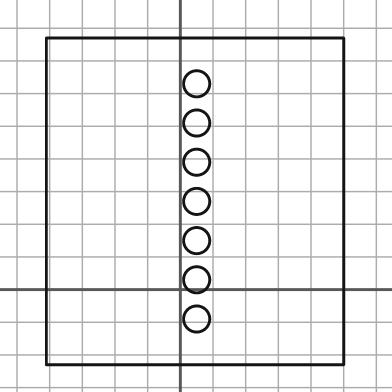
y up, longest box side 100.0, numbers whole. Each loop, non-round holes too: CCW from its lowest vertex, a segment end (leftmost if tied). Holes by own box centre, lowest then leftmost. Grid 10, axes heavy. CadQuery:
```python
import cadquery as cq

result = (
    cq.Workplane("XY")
    .moveTo(-41.0, -23.0)
    .lineTo(50.0, -23.0)
    .lineTo(50.0, 77.0)
    .lineTo(-41.0, 77.0)
    .close()
    .moveTo(5.0, -9.0)
    .circle(4.0)
    .moveTo(5.0, 3.0)
    .circle(4.0)
    .moveTo(5.0, 15.0)
    .circle(4.0)
    .moveTo(5.0, 27.0)
    .circle(4.0)
    .moveTo(5.0, 39.0)
    .circle(4.0)
    .moveTo(5.0, 51.0)
    .circle(4.0)
    .moveTo(5.0, 63.0)
    .circle(4.0)
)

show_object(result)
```